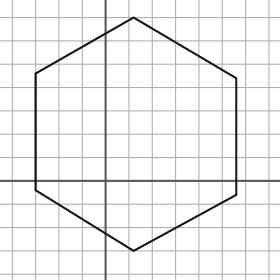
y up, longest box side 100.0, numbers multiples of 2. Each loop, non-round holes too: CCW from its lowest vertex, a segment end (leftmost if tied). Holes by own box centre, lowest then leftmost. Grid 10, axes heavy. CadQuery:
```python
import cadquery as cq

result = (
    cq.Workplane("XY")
    .moveTo(12.0, -30.0)
    .lineTo(56.0, -6.0)
    .lineTo(56.0, 44.0)
    .lineTo(12.0, 70.0)
    .lineTo(-30.0, 46.0)
    .lineTo(-30.0, -4.0)
    .close()
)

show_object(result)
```